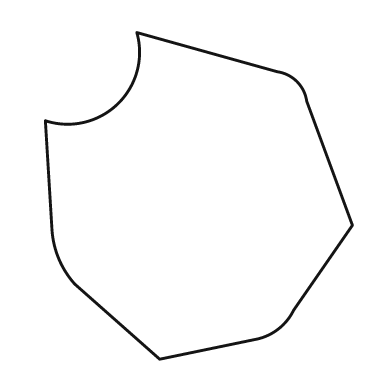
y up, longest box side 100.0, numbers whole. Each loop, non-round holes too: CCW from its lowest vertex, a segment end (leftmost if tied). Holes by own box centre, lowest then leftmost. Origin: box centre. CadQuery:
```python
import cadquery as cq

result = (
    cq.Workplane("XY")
    .moveTo(-12.0, -50.0)
    .lineTo(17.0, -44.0)
    .threePointArc((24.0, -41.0), (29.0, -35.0))
    .lineTo(47.0, -9.0)
    .lineTo(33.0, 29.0)
    .threePointArc((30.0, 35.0), (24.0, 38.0))
    .lineTo(-19.0, 50.0)
    .threePointArc((-25.0, 28.0), (-47.0, 23.0))
    .lineTo(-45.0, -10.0)
    .threePointArc((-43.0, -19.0), (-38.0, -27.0))
    .close()
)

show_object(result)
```